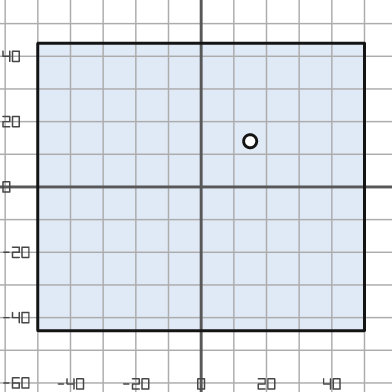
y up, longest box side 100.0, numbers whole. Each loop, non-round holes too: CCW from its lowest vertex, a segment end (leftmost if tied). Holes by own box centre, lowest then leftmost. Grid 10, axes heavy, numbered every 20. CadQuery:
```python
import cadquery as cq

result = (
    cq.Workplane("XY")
    .moveTo(-50.0, -44.0)
    .lineTo(50.0, -44.0)
    .lineTo(50.0, 44.0)
    .lineTo(-50.0, 44.0)
    .close()
    .moveTo(15.0, 14.0)
    .circle(2.0)
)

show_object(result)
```